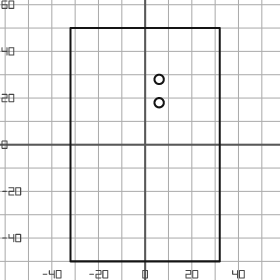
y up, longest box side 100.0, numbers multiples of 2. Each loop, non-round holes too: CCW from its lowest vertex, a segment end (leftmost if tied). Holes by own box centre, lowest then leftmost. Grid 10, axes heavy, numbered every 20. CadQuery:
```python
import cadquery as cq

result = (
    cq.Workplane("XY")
    .moveTo(-32.0, -50.0)
    .lineTo(32.0, -50.0)
    .lineTo(32.0, 50.0)
    .lineTo(-32.0, 50.0)
    .close()
    .moveTo(6.0, 18.0)
    .circle(2.0)
    .moveTo(6.0, 28.0)
    .circle(2.0)
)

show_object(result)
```